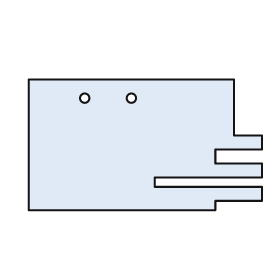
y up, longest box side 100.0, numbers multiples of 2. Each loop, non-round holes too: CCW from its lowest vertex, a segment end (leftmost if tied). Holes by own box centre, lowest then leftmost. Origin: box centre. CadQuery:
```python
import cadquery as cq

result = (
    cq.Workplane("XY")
    .moveTo(-50.0, -28.0)
    .lineTo(30.0, -28.0)
    .lineTo(30.0, -24.0)
    .lineTo(50.0, -24.0)
    .lineTo(50.0, -18.0)
    .lineTo(4.0, -18.0)
    .lineTo(4.0, -14.0)
    .lineTo(50.0, -14.0)
    .lineTo(50.0, -8.0)
    .lineTo(30.0, -8.0)
    .lineTo(30.0, -2.0)
    .lineTo(50.0, -2.0)
    .lineTo(50.0, 4.0)
    .lineTo(38.0, 4.0)
    .lineTo(38.0, 28.0)
    .lineTo(-50.0, 28.0)
    .close()
    .moveTo(-26.0, 20.0)
    .circle(2.0)
    .moveTo(-6.0, 20.0)
    .circle(2.0)
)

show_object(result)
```